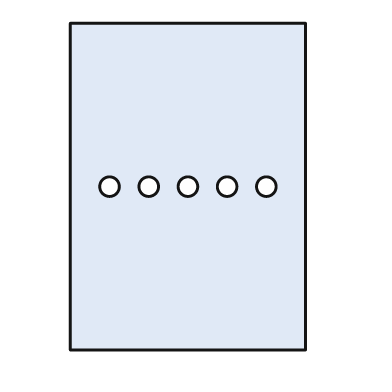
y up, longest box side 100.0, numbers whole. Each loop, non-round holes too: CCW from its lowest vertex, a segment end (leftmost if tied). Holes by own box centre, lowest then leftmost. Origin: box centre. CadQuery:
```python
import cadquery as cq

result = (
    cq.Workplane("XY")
    .moveTo(-36.0, -50.0)
    .lineTo(36.0, -50.0)
    .lineTo(36.0, 50.0)
    .lineTo(-36.0, 50.0)
    .close()
    .moveTo(-24.0, 0.0)
    .circle(3.0)
    .moveTo(-12.0, 0.0)
    .circle(3.0)
    .moveTo(0.0, 0.0)
    .circle(3.0)
    .moveTo(12.0, 0.0)
    .circle(3.0)
    .moveTo(24.0, 0.0)
    .circle(3.0)
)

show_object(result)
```